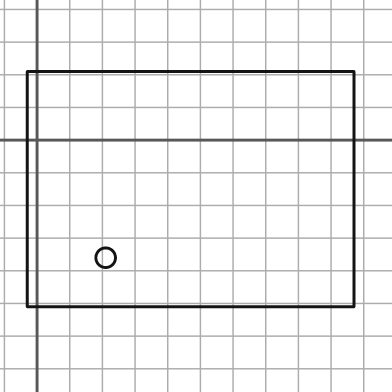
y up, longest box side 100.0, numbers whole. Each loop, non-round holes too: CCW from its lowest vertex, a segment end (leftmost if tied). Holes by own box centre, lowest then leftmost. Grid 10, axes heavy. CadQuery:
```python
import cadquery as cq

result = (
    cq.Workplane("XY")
    .moveTo(-3.0, -51.0)
    .lineTo(97.0, -51.0)
    .lineTo(97.0, 21.0)
    .lineTo(-3.0, 21.0)
    .close()
    .moveTo(21.0, -36.0)
    .circle(3.0)
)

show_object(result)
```